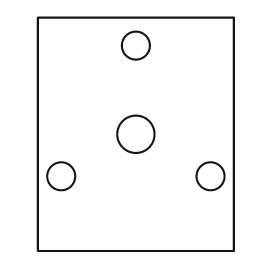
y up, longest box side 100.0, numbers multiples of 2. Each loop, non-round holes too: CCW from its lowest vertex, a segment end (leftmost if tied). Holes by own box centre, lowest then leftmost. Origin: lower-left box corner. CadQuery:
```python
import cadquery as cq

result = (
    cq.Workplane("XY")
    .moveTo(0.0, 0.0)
    .lineTo(84.0, 0.0)
    .lineTo(84.0, 100.0)
    .lineTo(0.0, 100.0)
    .close()
    .moveTo(10.0, 32.0)
    .circle(6.0)
    .moveTo(74.0, 32.0)
    .circle(6.0)
    .moveTo(42.0, 50.0)
    .circle(8.0)
    .moveTo(42.0, 88.0)
    .circle(6.0)
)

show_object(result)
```